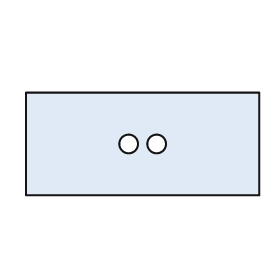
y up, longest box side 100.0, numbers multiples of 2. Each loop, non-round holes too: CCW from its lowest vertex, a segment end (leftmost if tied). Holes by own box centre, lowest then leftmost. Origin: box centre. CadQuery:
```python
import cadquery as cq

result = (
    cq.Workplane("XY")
    .moveTo(-50.0, -22.0)
    .lineTo(50.0, -22.0)
    .lineTo(50.0, 22.0)
    .lineTo(-50.0, 22.0)
    .close()
    .moveTo(-6.0, 0.0)
    .circle(4.0)
    .moveTo(6.0, 0.0)
    .circle(4.0)
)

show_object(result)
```